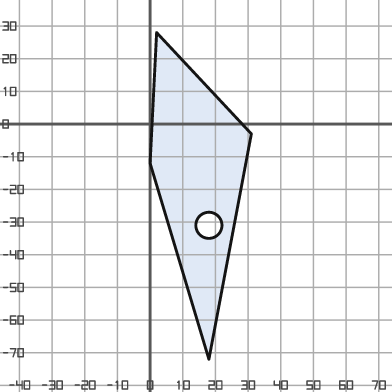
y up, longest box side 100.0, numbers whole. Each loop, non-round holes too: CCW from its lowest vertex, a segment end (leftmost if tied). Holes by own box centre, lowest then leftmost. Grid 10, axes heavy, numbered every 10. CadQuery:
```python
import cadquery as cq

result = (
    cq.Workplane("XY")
    .moveTo(18.0, -72.0)
    .lineTo(31.0, -3.0)
    .lineTo(2.0, 28.0)
    .lineTo(0.0, -12.0)
    .close()
    .moveTo(18.0, -31.0)
    .circle(4.0)
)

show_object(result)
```